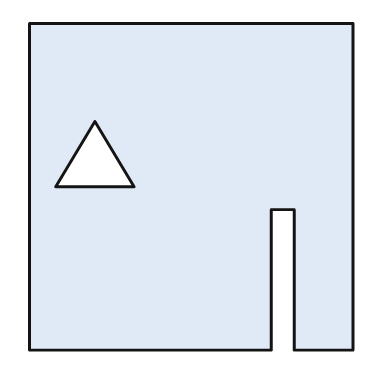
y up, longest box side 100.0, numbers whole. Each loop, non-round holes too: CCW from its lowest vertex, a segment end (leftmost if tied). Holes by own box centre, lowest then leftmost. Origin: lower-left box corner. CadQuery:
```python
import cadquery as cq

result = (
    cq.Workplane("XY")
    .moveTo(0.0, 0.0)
    .lineTo(74.0, 0.0)
    .lineTo(74.0, 43.0)
    .lineTo(81.0, 43.0)
    .lineTo(81.0, 0.0)
    .lineTo(99.0, 0.0)
    .lineTo(99.0, 100.0)
    .lineTo(0.0, 100.0)
    .close()
    .moveTo(8.0, 50.0)
    .lineTo(32.0, 50.0)
    .lineTo(20.0, 70.0)
    .close()
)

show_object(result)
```